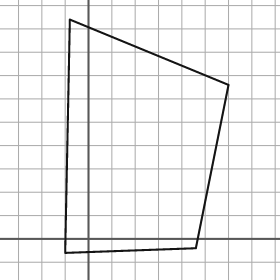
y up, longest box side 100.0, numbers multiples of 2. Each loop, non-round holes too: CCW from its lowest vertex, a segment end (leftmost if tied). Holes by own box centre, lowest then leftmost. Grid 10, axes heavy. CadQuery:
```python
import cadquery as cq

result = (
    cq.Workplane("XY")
    .moveTo(-10.0, -6.0)
    .lineTo(46.0, -4.0)
    .lineTo(60.0, 66.0)
    .lineTo(-8.0, 94.0)
    .close()
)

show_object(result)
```